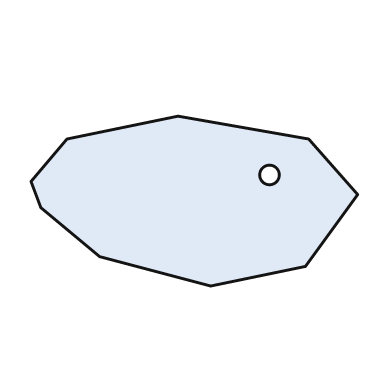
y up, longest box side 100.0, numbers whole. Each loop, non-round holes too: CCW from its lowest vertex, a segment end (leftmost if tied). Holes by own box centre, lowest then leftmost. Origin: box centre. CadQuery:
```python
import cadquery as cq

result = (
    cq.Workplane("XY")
    .moveTo(5.0, -26.0)
    .lineTo(34.0, -20.0)
    .lineTo(50.0, 2.0)
    .lineTo(35.0, 19.0)
    .lineTo(-5.0, 26.0)
    .lineTo(-39.0, 19.0)
    .lineTo(-50.0, 6.0)
    .lineTo(-47.0, -2.0)
    .lineTo(-29.0, -17.0)
    .close()
    .moveTo(23.0, 8.0)
    .circle(3.0)
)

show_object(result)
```